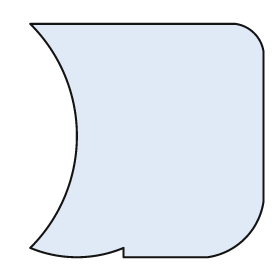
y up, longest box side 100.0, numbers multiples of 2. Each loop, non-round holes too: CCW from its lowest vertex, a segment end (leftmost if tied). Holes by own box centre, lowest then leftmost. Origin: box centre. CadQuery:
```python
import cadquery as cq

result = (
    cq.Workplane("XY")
    .moveTo(-10.0, -50.0)
    .lineTo(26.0, -50.0)
    .threePointArc((42.0, -42.0), (50.0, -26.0))
    .lineTo(50.0, 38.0)
    .threePointArc((46.0, 46.0), (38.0, 50.0))
    .lineTo(-50.0, 50.0)
    .threePointArc((-30.0, 2.0), (-50.0, -46.0))
    .threePointArc((-30.0, -50.0), (-10.0, -46.0))
    .close()
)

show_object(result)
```